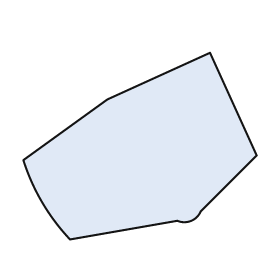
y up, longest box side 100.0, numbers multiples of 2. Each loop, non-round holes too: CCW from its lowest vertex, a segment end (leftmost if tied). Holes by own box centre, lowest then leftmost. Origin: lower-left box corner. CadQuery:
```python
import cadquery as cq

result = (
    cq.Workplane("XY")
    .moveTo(20.0, 0.0)
    .lineTo(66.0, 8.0)
    .threePointArc((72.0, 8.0), (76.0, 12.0))
    .lineTo(100.0, 36.0)
    .lineTo(80.0, 80.0)
    .lineTo(36.0, 60.0)
    .lineTo(0.0, 34.0)
    .threePointArc((8.0, 16.0), (20.0, 0.0))
    .close()
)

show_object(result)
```